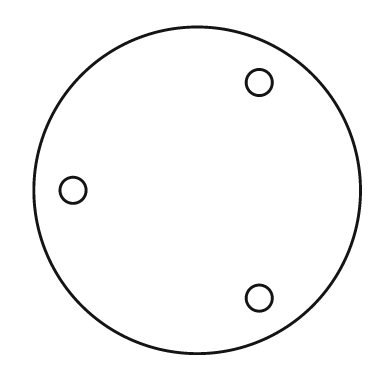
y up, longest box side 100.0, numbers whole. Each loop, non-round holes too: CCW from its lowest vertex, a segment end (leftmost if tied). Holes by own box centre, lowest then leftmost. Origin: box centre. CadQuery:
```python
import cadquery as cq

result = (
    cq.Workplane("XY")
    .moveTo(0.0, 0.0)
    .circle(50.0)
    .moveTo(19.0, -33.0)
    .circle(4.0)
    .moveTo(-38.0, 0.0)
    .circle(4.0)
    .moveTo(19.0, 33.0)
    .circle(4.0)
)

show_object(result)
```